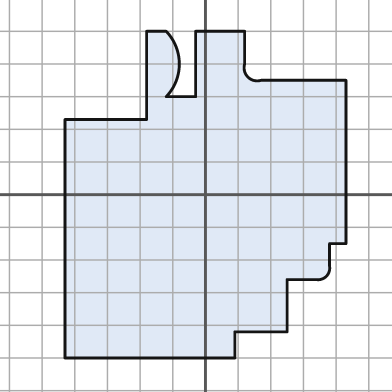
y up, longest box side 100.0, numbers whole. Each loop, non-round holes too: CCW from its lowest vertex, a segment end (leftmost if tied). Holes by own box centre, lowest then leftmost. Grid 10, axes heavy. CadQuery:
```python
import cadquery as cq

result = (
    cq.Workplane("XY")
    .moveTo(-43.0, -50.0)
    .lineTo(9.0, -50.0)
    .lineTo(9.0, -42.0)
    .lineTo(25.0, -42.0)
    .lineTo(25.0, -26.0)
    .lineTo(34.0, -26.0)
    .threePointArc((37.0, -25.0), (38.0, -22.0))
    .lineTo(38.0, -15.0)
    .lineTo(43.0, -15.0)
    .lineTo(43.0, 35.0)
    .lineTo(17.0, 35.0)
    .threePointArc((13.0, 36.0), (12.0, 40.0))
    .lineTo(12.0, 50.0)
    .lineTo(-3.0, 50.0)
    .lineTo(-3.0, 30.0)
    .lineTo(-12.0, 30.0)
    .threePointArc((-8.0, 40.0), (-12.0, 50.0))
    .lineTo(-18.0, 50.0)
    .lineTo(-18.0, 23.0)
    .lineTo(-43.0, 23.0)
    .close()
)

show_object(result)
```